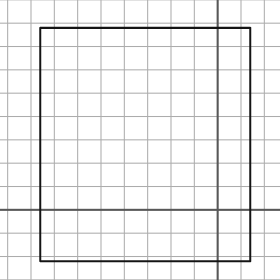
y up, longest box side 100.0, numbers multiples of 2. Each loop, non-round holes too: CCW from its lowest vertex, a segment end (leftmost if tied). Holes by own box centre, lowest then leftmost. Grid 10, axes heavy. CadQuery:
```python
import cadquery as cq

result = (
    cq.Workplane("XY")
    .moveTo(-76.0, -22.0)
    .lineTo(14.0, -22.0)
    .lineTo(14.0, 78.0)
    .lineTo(-76.0, 78.0)
    .close()
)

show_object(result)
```